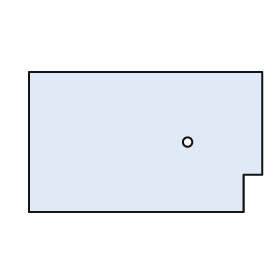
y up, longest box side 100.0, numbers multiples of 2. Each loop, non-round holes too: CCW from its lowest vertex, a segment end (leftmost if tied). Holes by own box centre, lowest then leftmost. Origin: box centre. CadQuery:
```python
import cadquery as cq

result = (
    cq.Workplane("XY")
    .moveTo(-50.0, -30.0)
    .lineTo(42.0, -30.0)
    .lineTo(42.0, -14.0)
    .lineTo(50.0, -14.0)
    .lineTo(50.0, 30.0)
    .lineTo(-50.0, 30.0)
    .close()
    .moveTo(18.0, 0.0)
    .circle(2.0)
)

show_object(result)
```